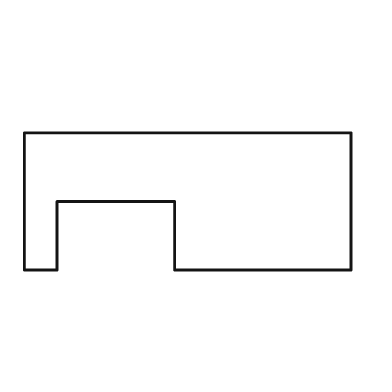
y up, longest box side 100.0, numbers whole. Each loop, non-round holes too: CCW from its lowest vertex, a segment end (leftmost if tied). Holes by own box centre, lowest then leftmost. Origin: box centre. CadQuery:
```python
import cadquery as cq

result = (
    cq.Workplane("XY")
    .moveTo(-50.0, -21.0)
    .lineTo(-40.0, -21.0)
    .lineTo(-40.0, 0.0)
    .lineTo(-4.0, 0.0)
    .lineTo(-4.0, -21.0)
    .lineTo(50.0, -21.0)
    .lineTo(50.0, 21.0)
    .lineTo(-50.0, 21.0)
    .close()
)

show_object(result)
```